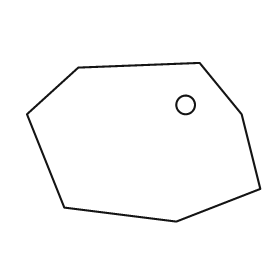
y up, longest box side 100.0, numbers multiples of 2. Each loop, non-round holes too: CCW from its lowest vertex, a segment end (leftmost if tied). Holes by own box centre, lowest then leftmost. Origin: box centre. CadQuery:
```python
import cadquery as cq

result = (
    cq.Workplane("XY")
    .moveTo(14.0, -34.0)
    .lineTo(50.0, -20.0)
    .lineTo(42.0, 12.0)
    .lineTo(24.0, 34.0)
    .lineTo(-28.0, 32.0)
    .lineTo(-50.0, 12.0)
    .lineTo(-34.0, -28.0)
    .close()
    .moveTo(18.0, 16.0)
    .circle(4.0)
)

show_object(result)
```